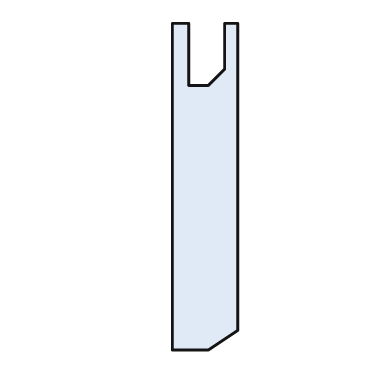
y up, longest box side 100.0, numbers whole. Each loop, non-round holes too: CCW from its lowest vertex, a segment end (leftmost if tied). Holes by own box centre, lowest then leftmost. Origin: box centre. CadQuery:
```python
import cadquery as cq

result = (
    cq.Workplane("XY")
    .moveTo(-10.0, -50.0)
    .lineTo(1.0, -50.0)
    .lineTo(10.0, -44.0)
    .lineTo(10.0, 50.0)
    .lineTo(6.0, 50.0)
    .lineTo(6.0, 36.0)
    .lineTo(1.0, 31.0)
    .lineTo(-5.0, 31.0)
    .lineTo(-5.0, 50.0)
    .lineTo(-10.0, 50.0)
    .close()
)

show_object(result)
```